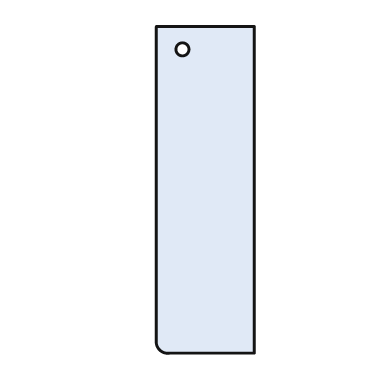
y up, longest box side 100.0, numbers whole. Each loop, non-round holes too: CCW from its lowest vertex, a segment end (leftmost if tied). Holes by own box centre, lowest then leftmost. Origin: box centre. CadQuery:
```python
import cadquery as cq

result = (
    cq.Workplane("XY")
    .moveTo(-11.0, -50.0)
    .lineTo(15.0, -50.0)
    .lineTo(15.0, 50.0)
    .lineTo(-15.0, 50.0)
    .lineTo(-15.0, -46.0)
    .threePointArc((-14.0, -49.0), (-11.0, -50.0))
    .close()
    .moveTo(-7.0, 43.0)
    .circle(2.0)
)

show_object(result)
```